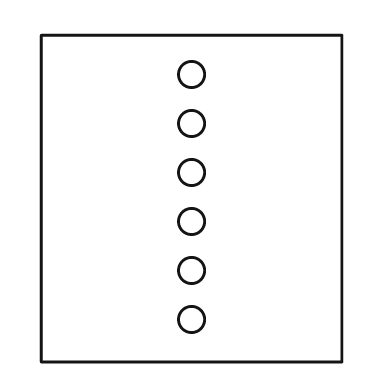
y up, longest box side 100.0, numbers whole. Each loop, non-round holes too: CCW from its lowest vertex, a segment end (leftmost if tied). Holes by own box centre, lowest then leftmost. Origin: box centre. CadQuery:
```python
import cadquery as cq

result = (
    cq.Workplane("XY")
    .moveTo(-46.0, -50.0)
    .lineTo(46.0, -50.0)
    .lineTo(46.0, 50.0)
    .lineTo(-46.0, 50.0)
    .close()
    .moveTo(0.0, -37.0)
    .circle(4.0)
    .moveTo(0.0, -22.0)
    .circle(4.0)
    .moveTo(0.0, -7.0)
    .circle(4.0)
    .moveTo(0.0, 8.0)
    .circle(4.0)
    .moveTo(0.0, 23.0)
    .circle(4.0)
    .moveTo(0.0, 38.0)
    .circle(4.0)
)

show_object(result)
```